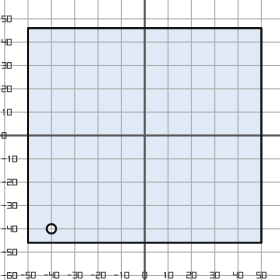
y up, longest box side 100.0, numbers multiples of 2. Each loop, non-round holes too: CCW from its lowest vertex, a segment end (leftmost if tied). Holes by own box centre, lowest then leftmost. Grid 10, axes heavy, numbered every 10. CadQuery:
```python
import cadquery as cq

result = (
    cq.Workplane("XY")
    .moveTo(-50.0, -46.0)
    .lineTo(50.0, -46.0)
    .lineTo(50.0, 46.0)
    .lineTo(-50.0, 46.0)
    .close()
    .moveTo(-40.0, -40.0)
    .circle(2.0)
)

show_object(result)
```